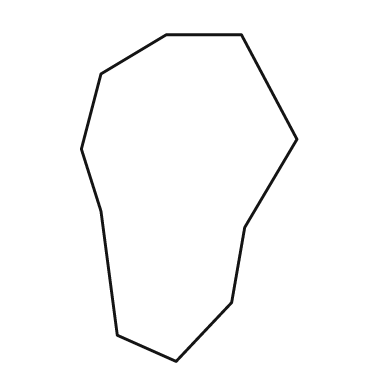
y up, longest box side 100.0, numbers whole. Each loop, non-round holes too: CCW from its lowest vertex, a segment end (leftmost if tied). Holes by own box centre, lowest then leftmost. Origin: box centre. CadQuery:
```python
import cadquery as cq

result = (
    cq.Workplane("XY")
    .moveTo(-4.0, -50.0)
    .lineTo(13.0, -32.0)
    .lineTo(17.0, -9.0)
    .lineTo(33.0, 18.0)
    .lineTo(16.0, 50.0)
    .lineTo(-7.0, 50.0)
    .lineTo(-27.0, 38.0)
    .lineTo(-33.0, 15.0)
    .lineTo(-27.0, -4.0)
    .lineTo(-22.0, -42.0)
    .close()
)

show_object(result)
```